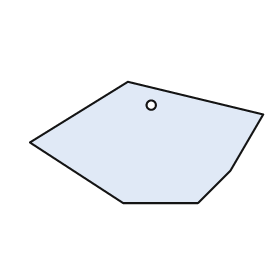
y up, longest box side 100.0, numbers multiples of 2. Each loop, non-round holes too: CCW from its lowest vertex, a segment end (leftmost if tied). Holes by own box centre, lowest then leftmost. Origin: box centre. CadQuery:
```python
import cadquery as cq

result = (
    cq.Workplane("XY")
    .moveTo(-10.0, -26.0)
    .lineTo(22.0, -26.0)
    .lineTo(36.0, -12.0)
    .lineTo(50.0, 12.0)
    .lineTo(-8.0, 26.0)
    .lineTo(-50.0, 0.0)
    .close()
    .moveTo(2.0, 16.0)
    .circle(2.0)
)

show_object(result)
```